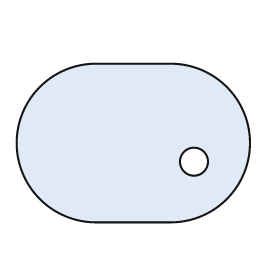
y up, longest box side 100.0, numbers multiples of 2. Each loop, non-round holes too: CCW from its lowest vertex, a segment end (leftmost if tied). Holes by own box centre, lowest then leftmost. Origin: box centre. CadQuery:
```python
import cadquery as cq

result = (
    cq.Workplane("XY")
    .moveTo(-16.0, -34.0)
    .lineTo(16.0, -34.0)
    .threePointArc((50.0, 0.0), (16.0, 34.0))
    .lineTo(-16.0, 34.0)
    .threePointArc((-50.0, 0.0), (-16.0, -34.0))
    .close()
    .moveTo(26.0, -8.0)
    .circle(6.0)
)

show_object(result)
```